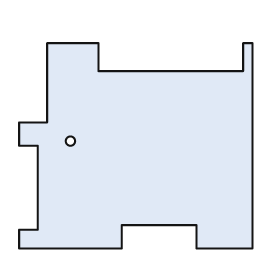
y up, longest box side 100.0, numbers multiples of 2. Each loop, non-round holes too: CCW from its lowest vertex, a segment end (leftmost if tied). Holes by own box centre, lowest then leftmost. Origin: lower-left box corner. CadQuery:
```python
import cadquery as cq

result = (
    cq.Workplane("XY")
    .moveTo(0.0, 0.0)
    .lineTo(44.0, 0.0)
    .lineTo(44.0, 10.0)
    .lineTo(76.0, 10.0)
    .lineTo(76.0, 0.0)
    .lineTo(100.0, 0.0)
    .lineTo(100.0, 88.0)
    .lineTo(96.0, 88.0)
    .lineTo(96.0, 76.0)
    .lineTo(34.0, 76.0)
    .lineTo(34.0, 88.0)
    .lineTo(12.0, 88.0)
    .lineTo(12.0, 54.0)
    .lineTo(0.0, 54.0)
    .lineTo(0.0, 44.0)
    .lineTo(8.0, 44.0)
    .lineTo(8.0, 8.0)
    .lineTo(0.0, 8.0)
    .close()
    .moveTo(22.0, 46.0)
    .circle(2.0)
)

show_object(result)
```